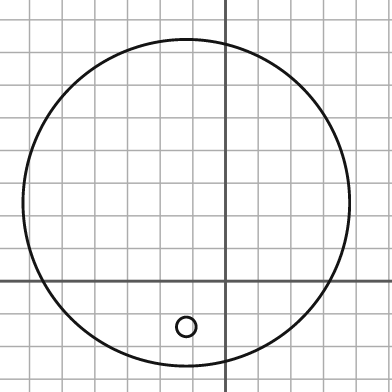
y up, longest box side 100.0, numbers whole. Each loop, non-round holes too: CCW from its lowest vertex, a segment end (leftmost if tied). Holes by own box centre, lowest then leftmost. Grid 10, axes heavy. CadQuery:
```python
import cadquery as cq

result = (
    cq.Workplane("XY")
    .moveTo(-12.0, 24.0)
    .circle(50.0)
    .moveTo(-12.0, -14.0)
    .circle(3.0)
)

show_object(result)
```